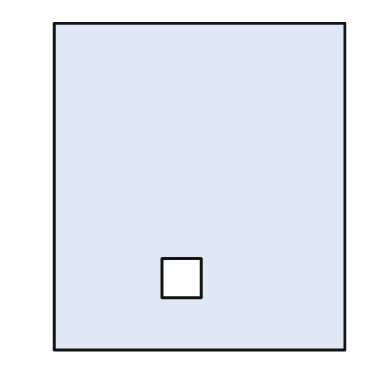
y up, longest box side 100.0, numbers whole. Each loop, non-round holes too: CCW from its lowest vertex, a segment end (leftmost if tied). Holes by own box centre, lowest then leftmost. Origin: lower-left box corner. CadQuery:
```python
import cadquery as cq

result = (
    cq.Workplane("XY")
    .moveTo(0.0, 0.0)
    .lineTo(89.0, 0.0)
    .lineTo(89.0, 100.0)
    .lineTo(0.0, 100.0)
    .close()
    .moveTo(33.0, 16.0)
    .lineTo(45.0, 16.0)
    .lineTo(45.0, 28.0)
    .lineTo(33.0, 28.0)
    .close()
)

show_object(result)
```